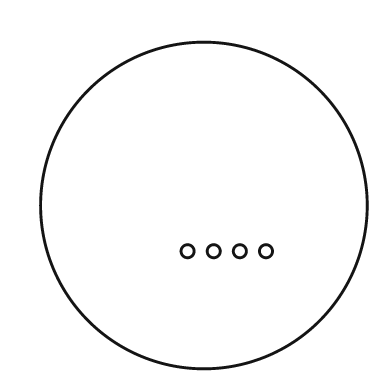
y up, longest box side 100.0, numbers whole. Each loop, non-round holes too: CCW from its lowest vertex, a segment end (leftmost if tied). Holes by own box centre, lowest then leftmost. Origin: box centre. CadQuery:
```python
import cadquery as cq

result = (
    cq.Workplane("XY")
    .moveTo(0.0, 0.0)
    .circle(50.0)
    .moveTo(-5.0, -14.0)
    .circle(2.0)
    .moveTo(3.0, -14.0)
    .circle(2.0)
    .moveTo(11.0, -14.0)
    .circle(2.0)
    .moveTo(19.0, -14.0)
    .circle(2.0)
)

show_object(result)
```